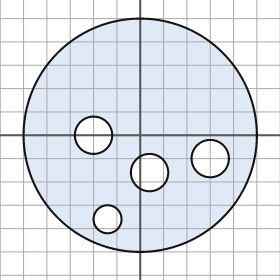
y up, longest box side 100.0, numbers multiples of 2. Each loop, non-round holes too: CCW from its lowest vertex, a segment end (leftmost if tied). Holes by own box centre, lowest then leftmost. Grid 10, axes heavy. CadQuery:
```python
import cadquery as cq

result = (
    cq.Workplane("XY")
    .moveTo(0.0, 0.0)
    .circle(50.0)
    .moveTo(-14.0, -36.0)
    .circle(6.0)
    .moveTo(4.0, -16.0)
    .circle(8.0)
    .moveTo(30.0, -10.0)
    .circle(8.0)
    .moveTo(-20.0, 0.0)
    .circle(8.0)
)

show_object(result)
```